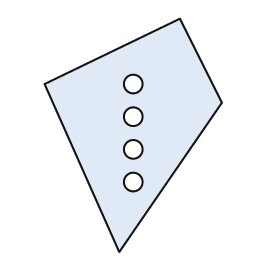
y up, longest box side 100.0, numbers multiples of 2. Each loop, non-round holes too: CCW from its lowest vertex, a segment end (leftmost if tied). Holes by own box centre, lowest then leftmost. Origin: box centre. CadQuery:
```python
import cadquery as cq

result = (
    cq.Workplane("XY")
    .moveTo(-6.0, -50.0)
    .lineTo(38.0, 14.0)
    .lineTo(20.0, 50.0)
    .lineTo(-38.0, 22.0)
    .close()
    .moveTo(0.0, -20.0)
    .circle(4.0)
    .moveTo(0.0, -6.0)
    .circle(4.0)
    .moveTo(0.0, 8.0)
    .circle(4.0)
    .moveTo(0.0, 22.0)
    .circle(4.0)
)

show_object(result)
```